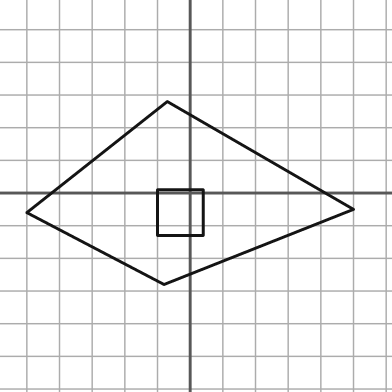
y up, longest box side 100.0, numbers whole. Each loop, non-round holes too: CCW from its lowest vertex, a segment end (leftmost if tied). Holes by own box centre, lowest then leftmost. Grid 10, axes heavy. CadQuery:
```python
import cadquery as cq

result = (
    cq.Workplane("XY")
    .moveTo(-8.0, -28.0)
    .lineTo(50.0, -5.0)
    .lineTo(-7.0, 28.0)
    .lineTo(-50.0, -6.0)
    .close()
    .moveTo(-10.0, -13.0)
    .lineTo(4.0, -13.0)
    .lineTo(4.0, 1.0)
    .lineTo(-10.0, 1.0)
    .close()
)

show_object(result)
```